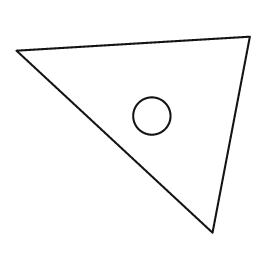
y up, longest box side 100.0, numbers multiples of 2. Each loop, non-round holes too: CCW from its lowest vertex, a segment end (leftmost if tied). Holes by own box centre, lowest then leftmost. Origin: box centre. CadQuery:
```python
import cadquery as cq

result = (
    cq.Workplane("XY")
    .moveTo(34.0, -42.0)
    .lineTo(50.0, 42.0)
    .lineTo(-50.0, 36.0)
    .close()
    .moveTo(8.0, 8.0)
    .circle(8.0)
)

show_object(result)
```